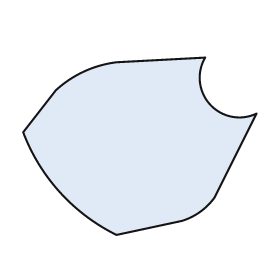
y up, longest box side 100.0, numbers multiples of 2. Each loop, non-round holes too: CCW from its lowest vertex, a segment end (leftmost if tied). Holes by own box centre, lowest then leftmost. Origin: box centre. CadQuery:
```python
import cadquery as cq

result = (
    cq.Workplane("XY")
    .moveTo(-10.0, -38.0)
    .lineTo(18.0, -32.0)
    .threePointArc((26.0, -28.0), (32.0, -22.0))
    .lineTo(50.0, 14.0)
    .threePointArc((30.0, 18.0), (28.0, 38.0))
    .lineTo(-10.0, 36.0)
    .threePointArc((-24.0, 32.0), (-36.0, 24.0))
    .lineTo(-50.0, 6.0)
    .threePointArc((-34.0, -20.0), (-10.0, -38.0))
    .close()
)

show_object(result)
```